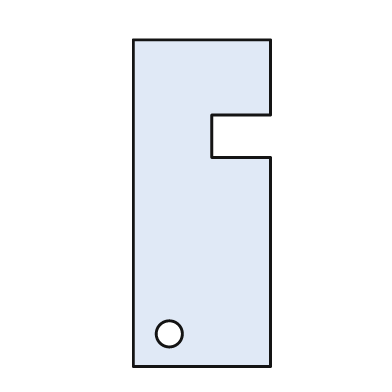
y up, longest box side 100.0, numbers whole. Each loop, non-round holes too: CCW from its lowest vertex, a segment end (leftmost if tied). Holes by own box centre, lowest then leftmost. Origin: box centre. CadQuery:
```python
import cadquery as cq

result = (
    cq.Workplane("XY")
    .moveTo(-21.0, -50.0)
    .lineTo(21.0, -50.0)
    .lineTo(21.0, 14.0)
    .lineTo(3.0, 14.0)
    .lineTo(3.0, 27.0)
    .lineTo(21.0, 27.0)
    .lineTo(21.0, 50.0)
    .lineTo(-21.0, 50.0)
    .close()
    .moveTo(-10.0, -40.0)
    .circle(4.0)
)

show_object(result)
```